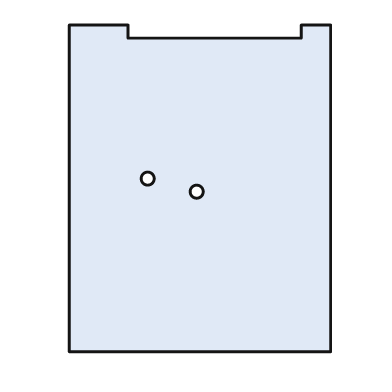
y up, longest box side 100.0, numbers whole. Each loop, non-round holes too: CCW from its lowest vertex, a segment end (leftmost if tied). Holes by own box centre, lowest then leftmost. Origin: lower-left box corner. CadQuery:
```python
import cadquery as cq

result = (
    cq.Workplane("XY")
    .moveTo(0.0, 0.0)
    .lineTo(80.0, 0.0)
    .lineTo(80.0, 100.0)
    .lineTo(71.0, 100.0)
    .lineTo(71.0, 96.0)
    .lineTo(18.0, 96.0)
    .lineTo(18.0, 100.0)
    .lineTo(0.0, 100.0)
    .close()
    .moveTo(39.0, 49.0)
    .circle(2.0)
    .moveTo(24.0, 53.0)
    .circle(2.0)
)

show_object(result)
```